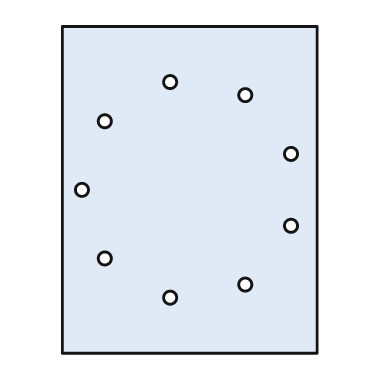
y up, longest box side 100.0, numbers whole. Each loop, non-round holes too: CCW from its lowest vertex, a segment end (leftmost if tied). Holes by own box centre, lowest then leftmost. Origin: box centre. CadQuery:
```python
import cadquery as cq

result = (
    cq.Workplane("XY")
    .moveTo(-39.0, -50.0)
    .lineTo(39.0, -50.0)
    .lineTo(39.0, 50.0)
    .lineTo(-39.0, 50.0)
    .close()
    .moveTo(-6.0, -33.0)
    .circle(2.0)
    .moveTo(17.0, -29.0)
    .circle(2.0)
    .moveTo(-26.0, -21.0)
    .circle(2.0)
    .moveTo(31.0, -11.0)
    .circle(2.0)
    .moveTo(-33.0, 0.0)
    .circle(2.0)
    .moveTo(31.0, 11.0)
    .circle(2.0)
    .moveTo(-26.0, 21.0)
    .circle(2.0)
    .moveTo(17.0, 29.0)
    .circle(2.0)
    .moveTo(-6.0, 33.0)
    .circle(2.0)
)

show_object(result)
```